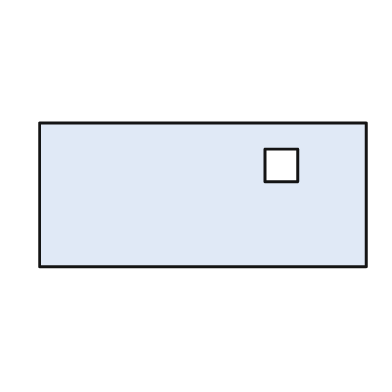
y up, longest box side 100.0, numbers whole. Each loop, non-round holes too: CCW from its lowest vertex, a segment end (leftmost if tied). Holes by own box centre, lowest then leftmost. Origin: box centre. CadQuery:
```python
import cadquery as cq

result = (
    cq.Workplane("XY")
    .moveTo(-50.0, -22.0)
    .lineTo(50.0, -22.0)
    .lineTo(50.0, 22.0)
    .lineTo(-50.0, 22.0)
    .close()
    .moveTo(19.0, 4.0)
    .lineTo(29.0, 4.0)
    .lineTo(29.0, 14.0)
    .lineTo(19.0, 14.0)
    .close()
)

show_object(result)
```